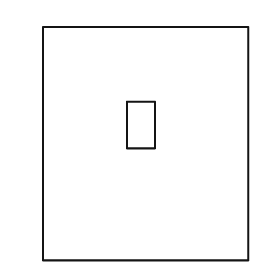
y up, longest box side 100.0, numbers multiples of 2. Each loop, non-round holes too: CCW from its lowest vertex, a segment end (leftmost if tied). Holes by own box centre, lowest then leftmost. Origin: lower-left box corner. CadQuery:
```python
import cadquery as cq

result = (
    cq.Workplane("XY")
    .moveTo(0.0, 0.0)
    .lineTo(88.0, 0.0)
    .lineTo(88.0, 100.0)
    .lineTo(0.0, 100.0)
    .close()
    .moveTo(36.0, 48.0)
    .lineTo(48.0, 48.0)
    .lineTo(48.0, 68.0)
    .lineTo(36.0, 68.0)
    .close()
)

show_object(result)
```